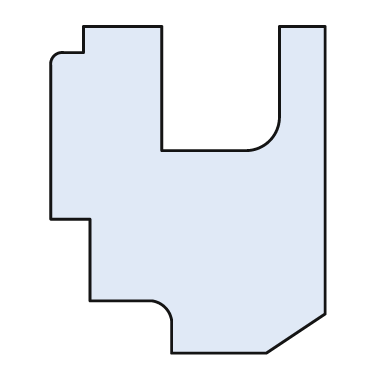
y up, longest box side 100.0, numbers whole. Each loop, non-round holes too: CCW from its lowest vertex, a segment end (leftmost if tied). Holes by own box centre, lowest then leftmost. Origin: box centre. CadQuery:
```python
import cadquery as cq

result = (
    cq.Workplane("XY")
    .moveTo(-5.0, -50.0)
    .lineTo(24.0, -50.0)
    .lineTo(42.0, -38.0)
    .lineTo(42.0, 50.0)
    .lineTo(28.0, 50.0)
    .lineTo(28.0, 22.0)
    .threePointArc((25.0, 15.0), (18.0, 12.0))
    .lineTo(-8.0, 12.0)
    .lineTo(-8.0, 50.0)
    .lineTo(-32.0, 50.0)
    .lineTo(-32.0, 42.0)
    .lineTo(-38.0, 42.0)
    .threePointArc((-41.0, 41.0), (-42.0, 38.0))
    .lineTo(-42.0, -9.0)
    .lineTo(-30.0, -9.0)
    .lineTo(-30.0, -34.0)
    .lineTo(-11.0, -34.0)
    .threePointArc((-7.0, -36.0), (-5.0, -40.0))
    .close()
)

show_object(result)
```